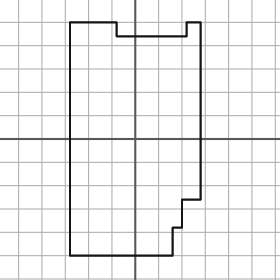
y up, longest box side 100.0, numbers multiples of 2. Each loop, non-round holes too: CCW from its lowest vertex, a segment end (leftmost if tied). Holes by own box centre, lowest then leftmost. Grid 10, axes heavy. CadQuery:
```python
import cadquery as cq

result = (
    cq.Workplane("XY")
    .moveTo(-28.0, -50.0)
    .lineTo(16.0, -50.0)
    .lineTo(16.0, -38.0)
    .lineTo(20.0, -38.0)
    .lineTo(20.0, -26.0)
    .lineTo(28.0, -26.0)
    .lineTo(28.0, 50.0)
    .lineTo(22.0, 50.0)
    .lineTo(22.0, 44.0)
    .lineTo(-8.0, 44.0)
    .lineTo(-8.0, 50.0)
    .lineTo(-28.0, 50.0)
    .close()
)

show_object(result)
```